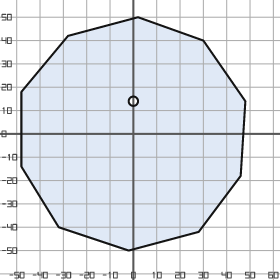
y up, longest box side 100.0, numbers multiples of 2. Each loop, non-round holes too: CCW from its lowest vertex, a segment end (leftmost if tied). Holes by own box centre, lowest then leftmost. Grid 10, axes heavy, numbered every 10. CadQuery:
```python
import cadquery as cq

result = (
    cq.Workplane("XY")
    .moveTo(-2.0, -50.0)
    .lineTo(28.0, -42.0)
    .lineTo(46.0, -18.0)
    .lineTo(48.0, 14.0)
    .lineTo(30.0, 40.0)
    .lineTo(2.0, 50.0)
    .lineTo(-28.0, 42.0)
    .lineTo(-48.0, 18.0)
    .lineTo(-48.0, -14.0)
    .lineTo(-32.0, -40.0)
    .close()
    .moveTo(0.0, 14.0)
    .circle(2.0)
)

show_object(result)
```